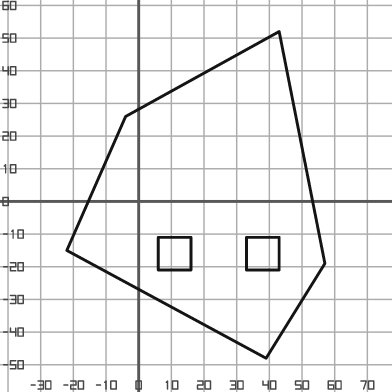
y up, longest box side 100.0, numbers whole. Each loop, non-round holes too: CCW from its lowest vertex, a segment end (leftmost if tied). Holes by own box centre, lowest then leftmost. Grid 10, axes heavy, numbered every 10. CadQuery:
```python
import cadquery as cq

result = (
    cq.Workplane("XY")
    .moveTo(39.0, -48.0)
    .lineTo(57.0, -19.0)
    .lineTo(43.0, 52.0)
    .lineTo(-4.0, 26.0)
    .lineTo(-22.0, -15.0)
    .close()
    .moveTo(6.0, -21.0)
    .lineTo(16.0, -21.0)
    .lineTo(16.0, -11.0)
    .lineTo(6.0, -11.0)
    .close()
    .moveTo(33.0, -21.0)
    .lineTo(43.0, -21.0)
    .lineTo(43.0, -11.0)
    .lineTo(33.0, -11.0)
    .close()
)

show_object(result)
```